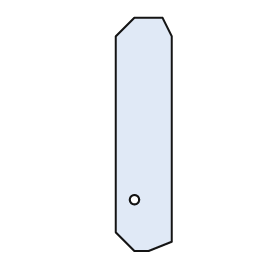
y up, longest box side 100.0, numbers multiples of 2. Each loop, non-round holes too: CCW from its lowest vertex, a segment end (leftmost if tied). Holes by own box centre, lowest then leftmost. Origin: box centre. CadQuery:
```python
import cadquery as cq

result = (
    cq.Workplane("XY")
    .moveTo(-4.0, -50.0)
    .lineTo(2.0, -50.0)
    .lineTo(12.0, -46.0)
    .lineTo(12.0, 42.0)
    .lineTo(8.0, 50.0)
    .lineTo(-4.0, 50.0)
    .lineTo(-12.0, 42.0)
    .lineTo(-12.0, -42.0)
    .close()
    .moveTo(-4.0, -28.0)
    .circle(2.0)
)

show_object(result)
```